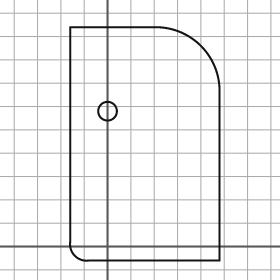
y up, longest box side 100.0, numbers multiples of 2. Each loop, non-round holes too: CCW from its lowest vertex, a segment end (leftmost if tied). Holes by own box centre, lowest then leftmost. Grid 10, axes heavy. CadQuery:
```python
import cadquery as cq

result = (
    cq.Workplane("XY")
    .moveTo(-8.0, -6.0)
    .lineTo(48.0, -6.0)
    .lineTo(48.0, 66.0)
    .threePointArc((40.0, 86.0), (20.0, 94.0))
    .lineTo(-16.0, 94.0)
    .lineTo(-16.0, 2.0)
    .threePointArc((-14.0, -4.0), (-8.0, -6.0))
    .close()
    .moveTo(0.0, 58.0)
    .circle(4.0)
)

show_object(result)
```